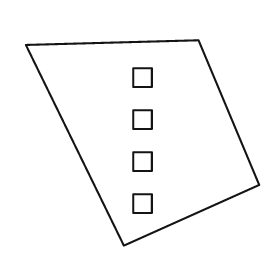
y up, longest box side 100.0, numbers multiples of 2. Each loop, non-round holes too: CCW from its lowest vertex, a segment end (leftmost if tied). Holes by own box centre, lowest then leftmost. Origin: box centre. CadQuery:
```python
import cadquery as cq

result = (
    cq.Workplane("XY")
    .moveTo(-8.0, -44.0)
    .lineTo(50.0, -18.0)
    .lineTo(24.0, 44.0)
    .lineTo(-50.0, 42.0)
    .close()
    .moveTo(-4.0, -30.0)
    .lineTo(4.0, -30.0)
    .lineTo(4.0, -22.0)
    .lineTo(-4.0, -22.0)
    .close()
    .moveTo(-4.0, -12.0)
    .lineTo(4.0, -12.0)
    .lineTo(4.0, -4.0)
    .lineTo(-4.0, -4.0)
    .close()
    .moveTo(-4.0, 6.0)
    .lineTo(4.0, 6.0)
    .lineTo(4.0, 14.0)
    .lineTo(-4.0, 14.0)
    .close()
    .moveTo(-4.0, 24.0)
    .lineTo(4.0, 24.0)
    .lineTo(4.0, 32.0)
    .lineTo(-4.0, 32.0)
    .close()
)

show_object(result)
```